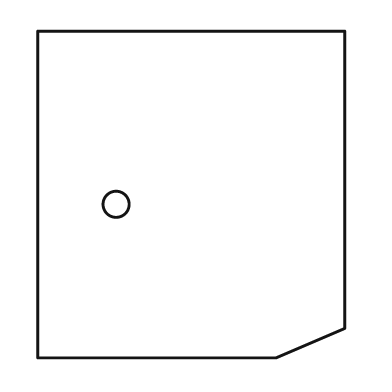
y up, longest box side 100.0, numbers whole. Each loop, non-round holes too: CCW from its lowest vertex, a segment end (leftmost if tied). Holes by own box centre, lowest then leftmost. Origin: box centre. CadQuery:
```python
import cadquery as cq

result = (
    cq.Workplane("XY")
    .moveTo(-47.0, -50.0)
    .lineTo(26.0, -50.0)
    .lineTo(47.0, -41.0)
    .lineTo(47.0, 50.0)
    .lineTo(-47.0, 50.0)
    .close()
    .moveTo(-23.0, -3.0)
    .circle(4.0)
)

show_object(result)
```